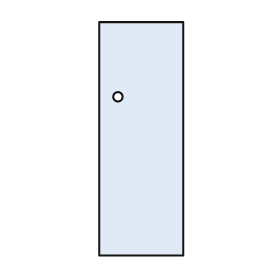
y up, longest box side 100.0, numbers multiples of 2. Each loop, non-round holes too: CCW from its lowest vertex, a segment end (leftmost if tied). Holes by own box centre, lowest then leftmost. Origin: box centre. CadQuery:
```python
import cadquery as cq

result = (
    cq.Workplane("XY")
    .moveTo(-18.0, -50.0)
    .lineTo(18.0, -50.0)
    .lineTo(18.0, 50.0)
    .lineTo(-18.0, 50.0)
    .close()
    .moveTo(-10.0, 18.0)
    .circle(2.0)
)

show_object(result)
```